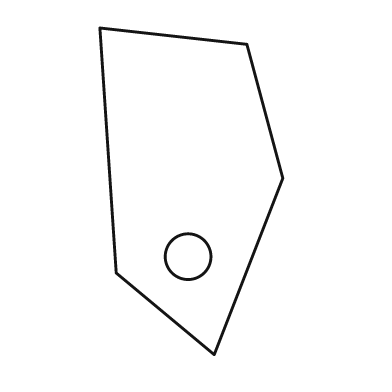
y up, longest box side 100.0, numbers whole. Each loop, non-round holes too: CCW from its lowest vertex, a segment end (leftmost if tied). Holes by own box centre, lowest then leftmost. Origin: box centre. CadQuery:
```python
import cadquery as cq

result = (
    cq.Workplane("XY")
    .moveTo(7.0, -50.0)
    .lineTo(28.0, 4.0)
    .lineTo(17.0, 45.0)
    .lineTo(-28.0, 50.0)
    .lineTo(-23.0, -25.0)
    .close()
    .moveTo(-1.0, -20.0)
    .circle(7.0)
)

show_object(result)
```